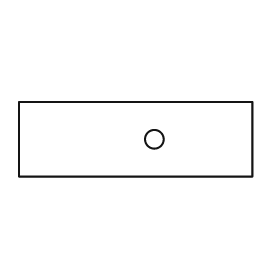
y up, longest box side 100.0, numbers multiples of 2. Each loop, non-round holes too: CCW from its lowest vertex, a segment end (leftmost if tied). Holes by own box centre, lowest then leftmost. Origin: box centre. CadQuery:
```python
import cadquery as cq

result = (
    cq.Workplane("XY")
    .moveTo(-50.0, -16.0)
    .lineTo(50.0, -16.0)
    .lineTo(50.0, 16.0)
    .lineTo(-50.0, 16.0)
    .close()
    .moveTo(8.0, 0.0)
    .circle(4.0)
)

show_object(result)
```